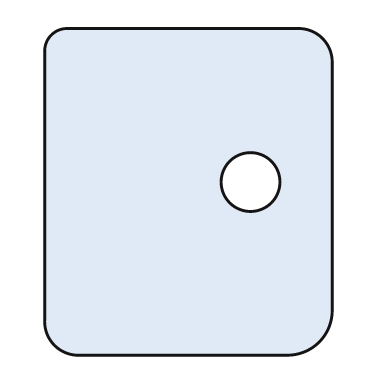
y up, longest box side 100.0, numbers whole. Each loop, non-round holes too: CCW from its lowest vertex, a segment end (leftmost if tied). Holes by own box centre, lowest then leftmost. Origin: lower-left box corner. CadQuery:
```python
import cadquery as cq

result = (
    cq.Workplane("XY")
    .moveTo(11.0, 0.0)
    .lineTo(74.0, 0.0)
    .threePointArc((84.0, 4.0), (88.0, 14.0))
    .lineTo(88.0, 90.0)
    .threePointArc((85.0, 97.0), (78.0, 100.0))
    .lineTo(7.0, 100.0)
    .threePointArc((2.0, 98.0), (0.0, 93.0))
    .lineTo(0.0, 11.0)
    .threePointArc((3.0, 3.0), (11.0, 0.0))
    .close()
    .moveTo(63.0, 53.0)
    .circle(9.0)
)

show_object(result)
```